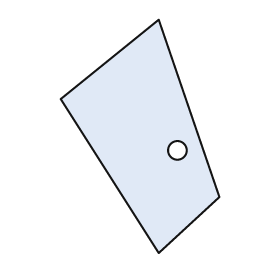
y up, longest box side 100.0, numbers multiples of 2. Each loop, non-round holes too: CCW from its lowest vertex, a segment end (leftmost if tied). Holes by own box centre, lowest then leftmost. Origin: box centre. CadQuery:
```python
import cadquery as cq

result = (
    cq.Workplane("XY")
    .moveTo(8.0, -50.0)
    .lineTo(34.0, -26.0)
    .lineTo(8.0, 50.0)
    .lineTo(-34.0, 16.0)
    .close()
    .moveTo(16.0, -6.0)
    .circle(4.0)
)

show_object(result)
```